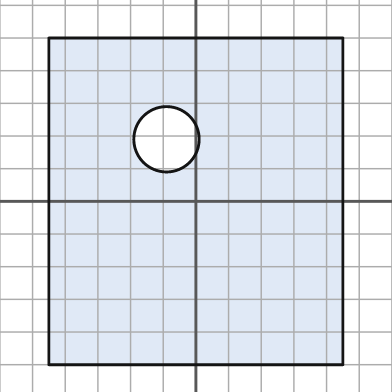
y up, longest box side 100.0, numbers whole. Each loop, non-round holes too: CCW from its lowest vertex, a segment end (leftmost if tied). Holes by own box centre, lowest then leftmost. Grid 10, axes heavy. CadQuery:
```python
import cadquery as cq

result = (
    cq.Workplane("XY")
    .moveTo(-45.0, -50.0)
    .lineTo(45.0, -50.0)
    .lineTo(45.0, 50.0)
    .lineTo(-45.0, 50.0)
    .close()
    .moveTo(-9.0, 19.0)
    .circle(10.0)
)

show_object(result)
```